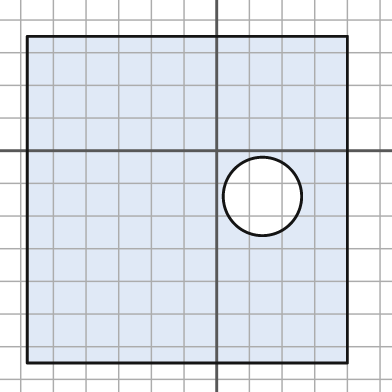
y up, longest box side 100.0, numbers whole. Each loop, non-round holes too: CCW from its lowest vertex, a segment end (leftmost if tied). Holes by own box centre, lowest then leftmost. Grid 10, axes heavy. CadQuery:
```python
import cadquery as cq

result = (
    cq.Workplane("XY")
    .moveTo(-58.0, -65.0)
    .lineTo(40.0, -65.0)
    .lineTo(40.0, 35.0)
    .lineTo(-58.0, 35.0)
    .close()
    .moveTo(14.0, -14.0)
    .circle(12.0)
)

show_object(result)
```